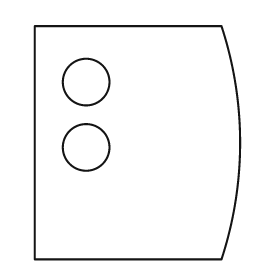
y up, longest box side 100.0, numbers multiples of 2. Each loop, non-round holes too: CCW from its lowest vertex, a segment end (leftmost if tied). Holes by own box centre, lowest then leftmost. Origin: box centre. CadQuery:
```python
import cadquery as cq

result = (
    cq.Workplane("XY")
    .moveTo(-44.0, -50.0)
    .lineTo(36.0, -50.0)
    .threePointArc((44.0, 0.0), (36.0, 50.0))
    .lineTo(-44.0, 50.0)
    .close()
    .moveTo(-22.0, -2.0)
    .circle(10.0)
    .moveTo(-22.0, 26.0)
    .circle(10.0)
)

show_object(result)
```